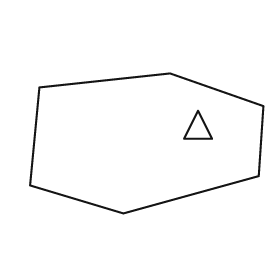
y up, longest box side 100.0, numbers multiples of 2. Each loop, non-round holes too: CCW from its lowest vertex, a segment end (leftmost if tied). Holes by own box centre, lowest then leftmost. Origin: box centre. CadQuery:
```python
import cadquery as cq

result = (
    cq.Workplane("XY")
    .moveTo(-10.0, -30.0)
    .lineTo(48.0, -14.0)
    .lineTo(50.0, 16.0)
    .lineTo(10.0, 30.0)
    .lineTo(-46.0, 24.0)
    .lineTo(-50.0, -18.0)
    .close()
    .moveTo(16.0, 2.0)
    .lineTo(28.0, 2.0)
    .lineTo(22.0, 14.0)
    .close()
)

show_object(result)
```